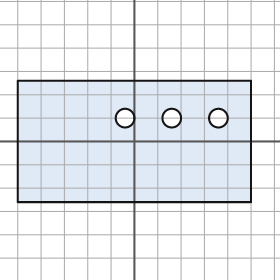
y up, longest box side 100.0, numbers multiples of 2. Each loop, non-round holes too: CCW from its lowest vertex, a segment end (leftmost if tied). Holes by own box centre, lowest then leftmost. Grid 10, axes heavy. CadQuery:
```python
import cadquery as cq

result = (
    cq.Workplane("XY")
    .moveTo(-50.0, -26.0)
    .lineTo(50.0, -26.0)
    .lineTo(50.0, 26.0)
    .lineTo(-50.0, 26.0)
    .close()
    .moveTo(-4.0, 10.0)
    .circle(4.0)
    .moveTo(16.0, 10.0)
    .circle(4.0)
    .moveTo(36.0, 10.0)
    .circle(4.0)
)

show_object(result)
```